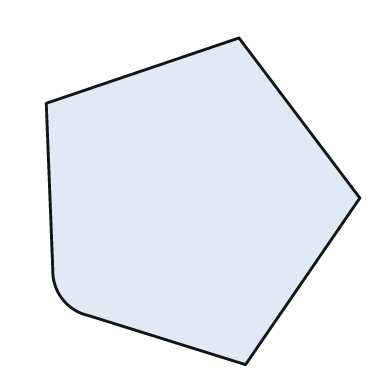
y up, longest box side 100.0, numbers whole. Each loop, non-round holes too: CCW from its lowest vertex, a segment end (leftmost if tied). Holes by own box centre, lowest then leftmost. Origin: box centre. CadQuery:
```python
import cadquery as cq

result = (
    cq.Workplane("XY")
    .moveTo(13.0, -50.0)
    .lineTo(48.0, 1.0)
    .lineTo(11.0, 50.0)
    .lineTo(-48.0, 30.0)
    .lineTo(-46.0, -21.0)
    .threePointArc((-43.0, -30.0), (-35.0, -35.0))
    .close()
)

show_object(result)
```